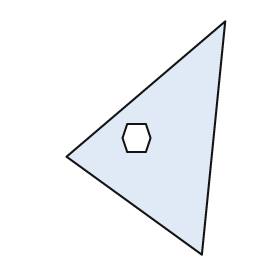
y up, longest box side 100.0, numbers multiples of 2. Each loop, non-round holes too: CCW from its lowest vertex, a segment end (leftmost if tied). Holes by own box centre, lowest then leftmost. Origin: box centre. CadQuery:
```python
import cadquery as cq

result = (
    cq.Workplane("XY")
    .moveTo(24.0, -50.0)
    .lineTo(34.0, 50.0)
    .lineTo(-34.0, -8.0)
    .close()
    .moveTo(-8.0, -6.0)
    .lineTo(0.0, -6.0)
    .lineTo(2.0, 0.0)
    .lineTo(0.0, 6.0)
    .lineTo(-8.0, 6.0)
    .lineTo(-10.0, 0.0)
    .close()
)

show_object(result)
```